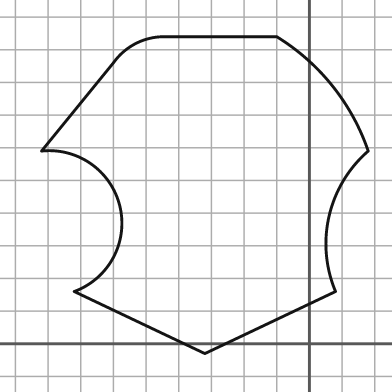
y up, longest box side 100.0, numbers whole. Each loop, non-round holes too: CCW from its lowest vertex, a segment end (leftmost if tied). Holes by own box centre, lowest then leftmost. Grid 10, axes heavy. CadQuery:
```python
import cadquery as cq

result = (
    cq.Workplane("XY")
    .moveTo(-32.0, -3.0)
    .lineTo(8.0, 16.0)
    .threePointArc((6.0, 39.0), (18.0, 59.0))
    .threePointArc((7.0, 79.0), (-10.0, 94.0))
    .lineTo(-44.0, 94.0)
    .threePointArc((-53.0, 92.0), (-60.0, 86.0))
    .lineTo(-82.0, 59.0)
    .threePointArc((-58.0, 42.0), (-72.0, 16.0))
    .close()
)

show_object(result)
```